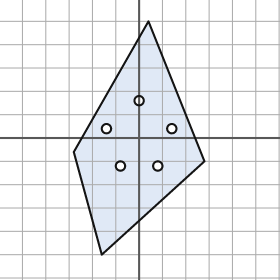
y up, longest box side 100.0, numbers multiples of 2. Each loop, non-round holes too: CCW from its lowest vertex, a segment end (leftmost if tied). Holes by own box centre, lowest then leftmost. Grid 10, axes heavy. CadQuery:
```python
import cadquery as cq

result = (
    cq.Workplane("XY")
    .moveTo(-16.0, -50.0)
    .lineTo(28.0, -10.0)
    .lineTo(4.0, 50.0)
    .lineTo(-28.0, -6.0)
    .close()
    .moveTo(-8.0, -12.0)
    .circle(2.0)
    .moveTo(8.0, -12.0)
    .circle(2.0)
    .moveTo(-14.0, 4.0)
    .circle(2.0)
    .moveTo(14.0, 4.0)
    .circle(2.0)
    .moveTo(0.0, 16.0)
    .circle(2.0)
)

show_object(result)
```